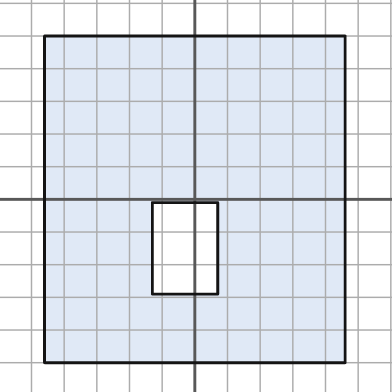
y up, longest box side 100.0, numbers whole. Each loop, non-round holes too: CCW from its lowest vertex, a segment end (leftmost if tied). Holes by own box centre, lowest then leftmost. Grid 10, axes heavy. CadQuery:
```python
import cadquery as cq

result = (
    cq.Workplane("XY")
    .moveTo(-46.0, -50.0)
    .lineTo(46.0, -50.0)
    .lineTo(46.0, 50.0)
    .lineTo(-46.0, 50.0)
    .close()
    .moveTo(-13.0, -29.0)
    .lineTo(7.0, -29.0)
    .lineTo(7.0, -1.0)
    .lineTo(-13.0, -1.0)
    .close()
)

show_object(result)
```